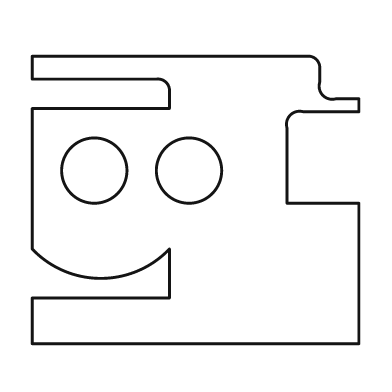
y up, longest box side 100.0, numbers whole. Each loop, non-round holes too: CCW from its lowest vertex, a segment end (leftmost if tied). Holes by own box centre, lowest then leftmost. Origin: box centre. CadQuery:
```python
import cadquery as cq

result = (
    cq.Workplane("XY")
    .moveTo(-50.0, -44.0)
    .lineTo(50.0, -44.0)
    .lineTo(50.0, -1.0)
    .lineTo(28.0, -1.0)
    .lineTo(28.0, 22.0)
    .threePointArc((29.0, 26.0), (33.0, 27.0))
    .lineTo(50.0, 27.0)
    .lineTo(50.0, 31.0)
    .lineTo(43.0, 31.0)
    .threePointArc((39.0, 32.0), (38.0, 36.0))
    .lineTo(38.0, 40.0)
    .threePointArc((37.0, 43.0), (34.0, 44.0))
    .lineTo(-50.0, 44.0)
    .lineTo(-50.0, 37.0)
    .lineTo(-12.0, 37.0)
    .threePointArc((-9.0, 36.0), (-8.0, 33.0))
    .lineTo(-8.0, 28.0)
    .lineTo(-50.0, 28.0)
    .lineTo(-50.0, -15.0)
    .threePointArc((-29.0, -24.0), (-8.0, -15.0))
    .lineTo(-8.0, -30.0)
    .lineTo(-50.0, -30.0)
    .close()
    .moveTo(-31.0, 9.0)
    .circle(10.0)
    .moveTo(-2.0, 9.0)
    .circle(10.0)
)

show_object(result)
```